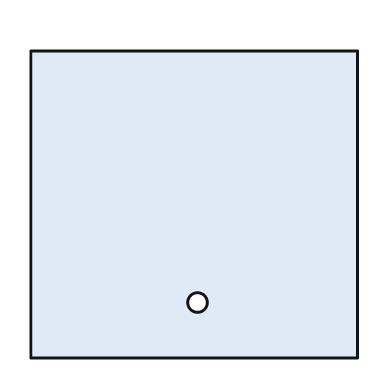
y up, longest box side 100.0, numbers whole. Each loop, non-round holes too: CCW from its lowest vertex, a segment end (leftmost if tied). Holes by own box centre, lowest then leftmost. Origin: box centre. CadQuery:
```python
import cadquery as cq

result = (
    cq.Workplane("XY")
    .moveTo(-50.0, -47.0)
    .lineTo(50.0, -47.0)
    .lineTo(50.0, 47.0)
    .lineTo(-50.0, 47.0)
    .close()
    .moveTo(1.0, -30.0)
    .circle(3.0)
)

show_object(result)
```